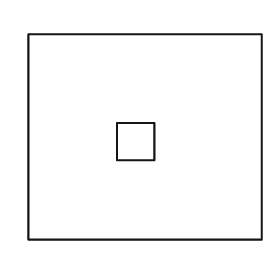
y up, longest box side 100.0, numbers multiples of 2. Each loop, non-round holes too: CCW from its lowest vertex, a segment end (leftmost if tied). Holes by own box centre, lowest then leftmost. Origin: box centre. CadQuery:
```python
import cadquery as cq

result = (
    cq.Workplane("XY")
    .moveTo(-50.0, -44.0)
    .lineTo(50.0, -44.0)
    .lineTo(50.0, 44.0)
    .lineTo(-50.0, 44.0)
    .close()
    .moveTo(-12.0, -10.0)
    .lineTo(4.0, -10.0)
    .lineTo(4.0, 6.0)
    .lineTo(-12.0, 6.0)
    .close()
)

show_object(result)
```